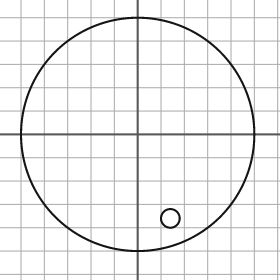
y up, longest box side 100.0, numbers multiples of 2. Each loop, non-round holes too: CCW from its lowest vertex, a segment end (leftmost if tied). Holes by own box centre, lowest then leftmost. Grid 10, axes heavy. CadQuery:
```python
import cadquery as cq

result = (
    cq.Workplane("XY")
    .moveTo(0.0, 0.0)
    .circle(50.0)
    .moveTo(14.0, -36.0)
    .circle(4.0)
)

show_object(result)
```